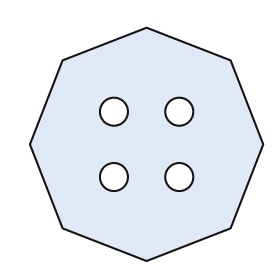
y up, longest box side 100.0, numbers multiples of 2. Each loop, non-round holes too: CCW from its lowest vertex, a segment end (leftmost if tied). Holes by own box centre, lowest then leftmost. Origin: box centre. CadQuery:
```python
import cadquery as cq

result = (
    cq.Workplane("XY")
    .moveTo(0.0, -50.0)
    .lineTo(36.0, -36.0)
    .lineTo(50.0, 0.0)
    .lineTo(36.0, 36.0)
    .lineTo(0.0, 50.0)
    .lineTo(-36.0, 36.0)
    .lineTo(-50.0, 0.0)
    .lineTo(-36.0, -36.0)
    .close()
    .moveTo(-14.0, -14.0)
    .circle(6.0)
    .moveTo(14.0, -14.0)
    .circle(6.0)
    .moveTo(-14.0, 14.0)
    .circle(6.0)
    .moveTo(14.0, 14.0)
    .circle(6.0)
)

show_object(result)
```